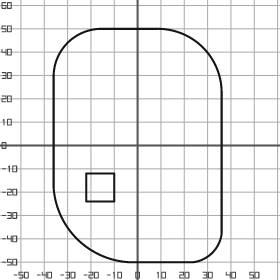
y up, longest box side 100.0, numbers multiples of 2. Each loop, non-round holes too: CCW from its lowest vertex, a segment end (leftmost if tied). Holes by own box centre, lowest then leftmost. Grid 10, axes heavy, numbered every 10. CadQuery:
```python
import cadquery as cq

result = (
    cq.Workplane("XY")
    .moveTo(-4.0, -50.0)
    .lineTo(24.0, -50.0)
    .threePointArc((32.0, -46.0), (36.0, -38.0))
    .lineTo(36.0, 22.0)
    .threePointArc((28.0, 42.0), (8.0, 50.0))
    .lineTo(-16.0, 50.0)
    .threePointArc((-30.0, 44.0), (-36.0, 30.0))
    .lineTo(-36.0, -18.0)
    .threePointArc((-26.0, -40.0), (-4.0, -50.0))
    .close()
    .moveTo(-22.0, -24.0)
    .lineTo(-10.0, -24.0)
    .lineTo(-10.0, -12.0)
    .lineTo(-22.0, -12.0)
    .close()
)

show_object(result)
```